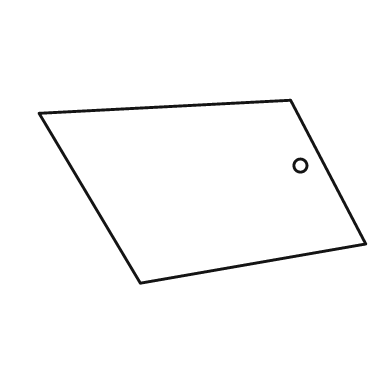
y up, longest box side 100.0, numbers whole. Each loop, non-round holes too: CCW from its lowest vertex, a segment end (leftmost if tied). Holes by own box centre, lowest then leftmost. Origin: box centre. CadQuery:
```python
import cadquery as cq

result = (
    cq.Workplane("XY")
    .moveTo(-19.0, -28.0)
    .lineTo(50.0, -16.0)
    .lineTo(27.0, 28.0)
    .lineTo(-50.0, 24.0)
    .close()
    .moveTo(30.0, 8.0)
    .circle(2.0)
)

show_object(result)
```